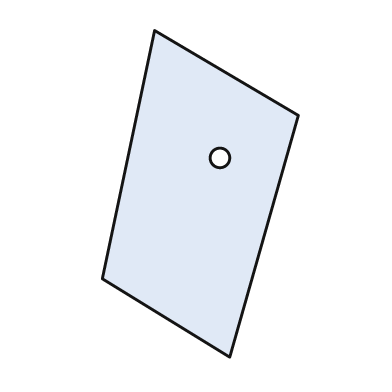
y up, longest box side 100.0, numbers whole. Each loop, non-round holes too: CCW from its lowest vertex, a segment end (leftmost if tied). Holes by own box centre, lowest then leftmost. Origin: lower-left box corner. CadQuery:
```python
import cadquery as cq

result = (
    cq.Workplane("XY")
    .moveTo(39.0, 0.0)
    .lineTo(60.0, 74.0)
    .lineTo(16.0, 100.0)
    .lineTo(0.0, 24.0)
    .close()
    .moveTo(36.0, 61.0)
    .circle(3.0)
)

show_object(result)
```